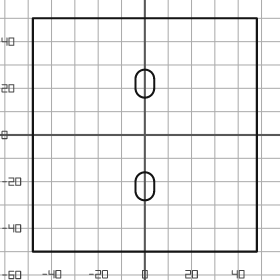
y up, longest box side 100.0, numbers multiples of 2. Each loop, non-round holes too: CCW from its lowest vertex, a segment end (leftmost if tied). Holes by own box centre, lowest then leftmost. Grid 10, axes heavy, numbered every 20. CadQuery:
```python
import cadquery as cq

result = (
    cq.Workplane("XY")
    .moveTo(-48.0, -50.0)
    .lineTo(48.0, -50.0)
    .lineTo(48.0, 50.0)
    .lineTo(-48.0, 50.0)
    .close()
    .moveTo(-4.0, -24.0)
    .threePointArc((0.0, -28.0), (4.0, -24.0))
    .lineTo(4.0, -20.0)
    .threePointArc((0.0, -16.0), (-4.0, -20.0))
    .close()
    .moveTo(-4.0, 20.0)
    .threePointArc((0.0, 16.0), (4.0, 20.0))
    .lineTo(4.0, 24.0)
    .threePointArc((0.0, 28.0), (-4.0, 24.0))
    .close()
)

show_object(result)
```